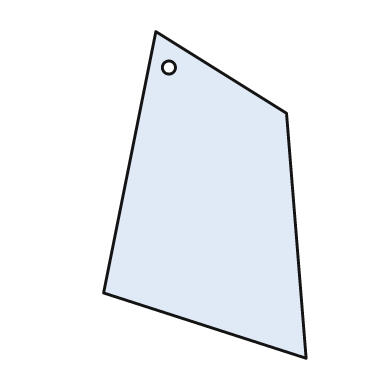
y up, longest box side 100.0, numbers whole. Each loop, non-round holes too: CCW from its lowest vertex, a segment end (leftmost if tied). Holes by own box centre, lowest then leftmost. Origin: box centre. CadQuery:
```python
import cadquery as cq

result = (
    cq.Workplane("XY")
    .moveTo(31.0, -50.0)
    .lineTo(25.0, 25.0)
    .lineTo(-15.0, 50.0)
    .lineTo(-31.0, -30.0)
    .close()
    .moveTo(-11.0, 39.0)
    .circle(2.0)
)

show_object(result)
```